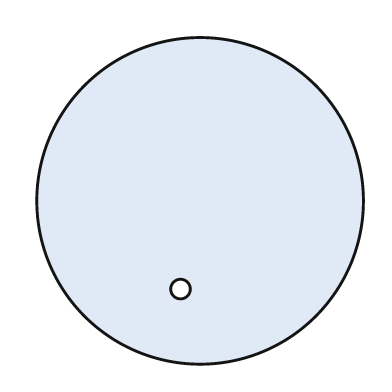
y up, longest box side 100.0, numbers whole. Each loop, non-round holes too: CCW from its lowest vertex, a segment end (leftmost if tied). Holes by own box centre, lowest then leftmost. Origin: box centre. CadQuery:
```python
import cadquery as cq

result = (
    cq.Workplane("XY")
    .moveTo(0.0, 0.0)
    .circle(50.0)
    .moveTo(-6.0, -27.0)
    .circle(3.0)
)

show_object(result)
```